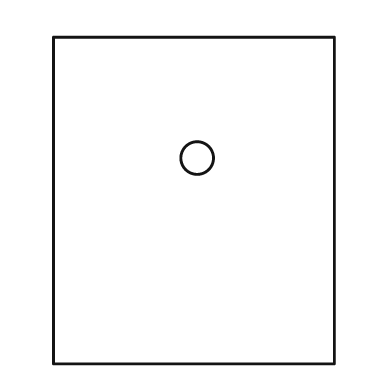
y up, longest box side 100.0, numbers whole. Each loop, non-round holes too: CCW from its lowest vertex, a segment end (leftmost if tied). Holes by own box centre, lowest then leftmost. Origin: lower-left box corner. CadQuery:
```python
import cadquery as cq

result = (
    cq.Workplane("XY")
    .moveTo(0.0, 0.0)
    .lineTo(86.0, 0.0)
    .lineTo(86.0, 100.0)
    .lineTo(0.0, 100.0)
    .close()
    .moveTo(44.0, 63.0)
    .circle(5.0)
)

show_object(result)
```